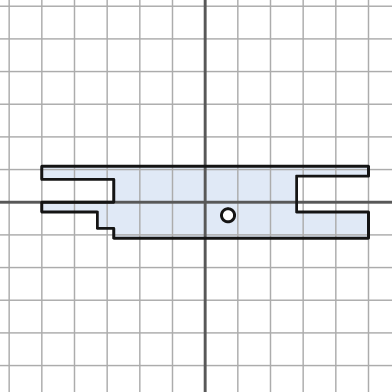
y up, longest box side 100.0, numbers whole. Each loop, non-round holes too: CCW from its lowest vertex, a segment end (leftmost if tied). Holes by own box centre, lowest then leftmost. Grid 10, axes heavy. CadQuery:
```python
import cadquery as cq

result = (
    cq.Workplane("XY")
    .moveTo(-28.0, -11.0)
    .lineTo(50.0, -11.0)
    .lineTo(50.0, -3.0)
    .lineTo(28.0, -3.0)
    .lineTo(28.0, 8.0)
    .lineTo(50.0, 8.0)
    .lineTo(50.0, 11.0)
    .lineTo(-50.0, 11.0)
    .lineTo(-50.0, 7.0)
    .lineTo(-28.0, 7.0)
    .lineTo(-28.0, 0.0)
    .lineTo(-50.0, 0.0)
    .lineTo(-50.0, -3.0)
    .lineTo(-33.0, -3.0)
    .lineTo(-33.0, -8.0)
    .lineTo(-28.0, -8.0)
    .close()
    .moveTo(7.0, -4.0)
    .circle(2.0)
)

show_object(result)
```